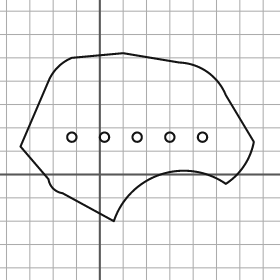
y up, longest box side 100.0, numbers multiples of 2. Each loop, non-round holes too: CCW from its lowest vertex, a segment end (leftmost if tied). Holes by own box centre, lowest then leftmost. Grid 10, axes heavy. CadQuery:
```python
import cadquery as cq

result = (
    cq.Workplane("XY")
    .moveTo(6.0, -20.0)
    .threePointArc((26.0, 0.0), (54.0, -4.0))
    .threePointArc((62.0, 4.0), (66.0, 14.0))
    .lineTo(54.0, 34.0)
    .threePointArc((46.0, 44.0), (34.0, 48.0))
    .lineTo(10.0, 52.0)
    .lineTo(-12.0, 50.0)
    .threePointArc((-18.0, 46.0), (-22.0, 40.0))
    .lineTo(-34.0, 12.0)
    .lineTo(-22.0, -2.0)
    .threePointArc((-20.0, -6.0), (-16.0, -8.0))
    .close()
    .moveTo(-12.0, 16.0)
    .circle(2.0)
    .moveTo(2.0, 16.0)
    .circle(2.0)
    .moveTo(16.0, 16.0)
    .circle(2.0)
    .moveTo(30.0, 16.0)
    .circle(2.0)
    .moveTo(44.0, 16.0)
    .circle(2.0)
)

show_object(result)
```